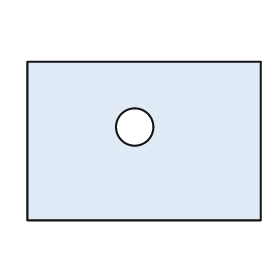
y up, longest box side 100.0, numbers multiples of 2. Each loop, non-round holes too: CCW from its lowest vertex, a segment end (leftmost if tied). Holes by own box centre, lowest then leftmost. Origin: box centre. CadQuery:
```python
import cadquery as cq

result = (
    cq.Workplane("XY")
    .moveTo(-50.0, -34.0)
    .lineTo(50.0, -34.0)
    .lineTo(50.0, 34.0)
    .lineTo(-50.0, 34.0)
    .close()
    .moveTo(-4.0, 6.0)
    .circle(8.0)
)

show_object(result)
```